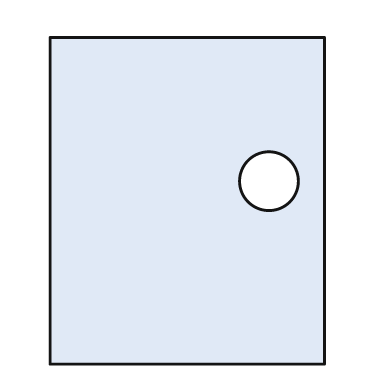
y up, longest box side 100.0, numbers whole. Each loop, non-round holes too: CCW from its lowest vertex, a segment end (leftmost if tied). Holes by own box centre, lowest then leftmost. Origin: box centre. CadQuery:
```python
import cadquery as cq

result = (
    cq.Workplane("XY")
    .moveTo(-42.0, -50.0)
    .lineTo(42.0, -50.0)
    .lineTo(42.0, 50.0)
    .lineTo(-42.0, 50.0)
    .close()
    .moveTo(25.0, 6.0)
    .circle(9.0)
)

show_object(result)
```